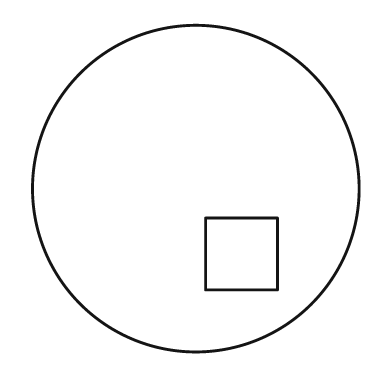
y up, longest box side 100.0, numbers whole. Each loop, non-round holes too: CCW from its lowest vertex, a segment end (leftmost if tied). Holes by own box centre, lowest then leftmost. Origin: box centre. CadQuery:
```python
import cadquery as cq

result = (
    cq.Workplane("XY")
    .moveTo(0.0, 0.0)
    .circle(50.0)
    .moveTo(3.0, -31.0)
    .lineTo(25.0, -31.0)
    .lineTo(25.0, -9.0)
    .lineTo(3.0, -9.0)
    .close()
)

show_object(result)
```